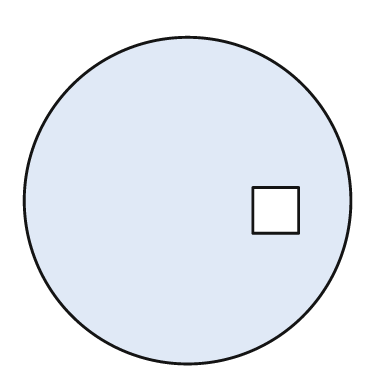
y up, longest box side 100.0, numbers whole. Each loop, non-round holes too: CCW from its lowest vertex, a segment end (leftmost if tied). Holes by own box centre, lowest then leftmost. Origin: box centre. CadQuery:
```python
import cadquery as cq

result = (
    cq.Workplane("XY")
    .moveTo(0.0, 0.0)
    .circle(50.0)
    .moveTo(20.0, -10.0)
    .lineTo(34.0, -10.0)
    .lineTo(34.0, 4.0)
    .lineTo(20.0, 4.0)
    .close()
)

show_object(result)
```